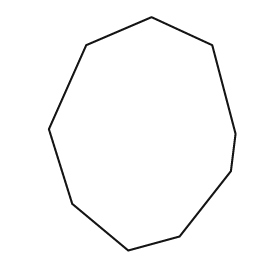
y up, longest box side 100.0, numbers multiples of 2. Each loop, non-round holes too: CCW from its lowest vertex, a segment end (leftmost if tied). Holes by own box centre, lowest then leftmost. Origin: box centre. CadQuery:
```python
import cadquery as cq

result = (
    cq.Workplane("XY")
    .moveTo(-6.0, -50.0)
    .lineTo(16.0, -44.0)
    .lineTo(38.0, -16.0)
    .lineTo(40.0, 0.0)
    .lineTo(30.0, 38.0)
    .lineTo(4.0, 50.0)
    .lineTo(-24.0, 38.0)
    .lineTo(-40.0, 2.0)
    .lineTo(-30.0, -30.0)
    .close()
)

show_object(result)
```